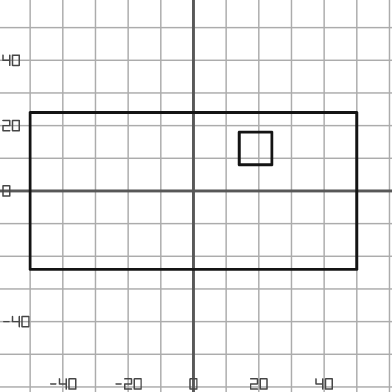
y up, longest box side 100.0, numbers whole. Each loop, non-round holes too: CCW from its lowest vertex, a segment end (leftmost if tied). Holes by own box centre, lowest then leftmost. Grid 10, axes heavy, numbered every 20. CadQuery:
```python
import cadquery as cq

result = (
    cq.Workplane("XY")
    .moveTo(-50.0, -24.0)
    .lineTo(50.0, -24.0)
    .lineTo(50.0, 24.0)
    .lineTo(-50.0, 24.0)
    .close()
    .moveTo(14.0, 8.0)
    .lineTo(24.0, 8.0)
    .lineTo(24.0, 18.0)
    .lineTo(14.0, 18.0)
    .close()
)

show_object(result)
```